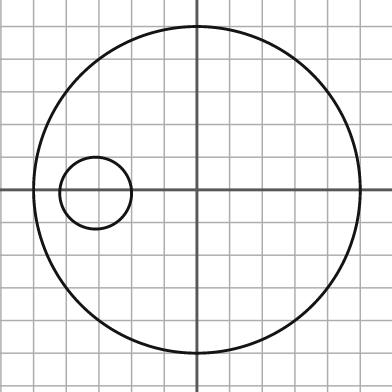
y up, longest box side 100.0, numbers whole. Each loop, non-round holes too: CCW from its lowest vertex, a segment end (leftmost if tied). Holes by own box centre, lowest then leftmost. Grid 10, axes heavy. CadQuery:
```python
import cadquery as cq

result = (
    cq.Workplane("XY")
    .moveTo(0.0, 0.0)
    .circle(50.0)
    .moveTo(-31.0, -1.0)
    .circle(11.0)
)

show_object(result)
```